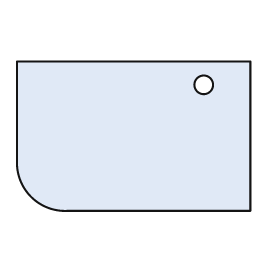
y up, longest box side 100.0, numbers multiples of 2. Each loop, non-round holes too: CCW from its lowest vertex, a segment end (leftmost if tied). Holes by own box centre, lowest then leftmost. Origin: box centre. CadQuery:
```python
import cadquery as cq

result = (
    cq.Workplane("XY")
    .moveTo(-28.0, -32.0)
    .lineTo(50.0, -32.0)
    .lineTo(50.0, 32.0)
    .lineTo(-50.0, 32.0)
    .lineTo(-50.0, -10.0)
    .threePointArc((-44.0, -26.0), (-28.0, -32.0))
    .close()
    .moveTo(30.0, 22.0)
    .circle(4.0)
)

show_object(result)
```